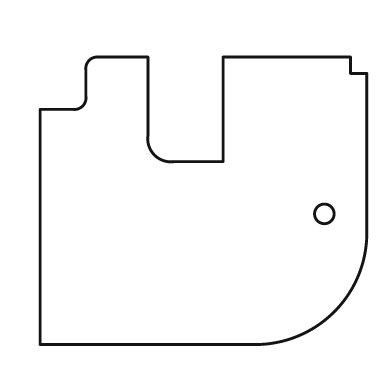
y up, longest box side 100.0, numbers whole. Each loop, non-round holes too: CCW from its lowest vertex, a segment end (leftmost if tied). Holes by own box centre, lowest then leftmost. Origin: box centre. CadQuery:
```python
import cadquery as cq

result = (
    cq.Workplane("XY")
    .moveTo(-50.0, -44.0)
    .lineTo(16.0, -44.0)
    .threePointArc((40.0, -34.0), (50.0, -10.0))
    .lineTo(50.0, 39.0)
    .lineTo(45.0, 39.0)
    .lineTo(45.0, 44.0)
    .lineTo(6.0, 44.0)
    .lineTo(6.0, 12.0)
    .lineTo(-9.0, 12.0)
    .threePointArc((-15.0, 14.0), (-17.0, 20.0))
    .lineTo(-17.0, 44.0)
    .lineTo(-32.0, 44.0)
    .threePointArc((-35.0, 43.0), (-36.0, 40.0))
    .lineTo(-36.0, 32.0)
    .threePointArc((-37.0, 29.0), (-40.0, 28.0))
    .lineTo(-50.0, 28.0)
    .close()
    .moveTo(37.0, -4.0)
    .circle(3.0)
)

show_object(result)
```